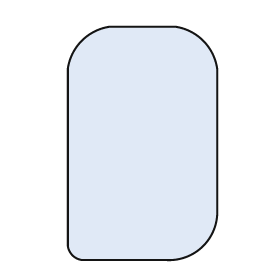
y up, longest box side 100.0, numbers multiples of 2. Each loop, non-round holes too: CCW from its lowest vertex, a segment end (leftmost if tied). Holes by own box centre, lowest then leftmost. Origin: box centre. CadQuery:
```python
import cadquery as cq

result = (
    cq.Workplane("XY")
    .moveTo(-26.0, -50.0)
    .lineTo(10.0, -50.0)
    .threePointArc((26.0, -44.0), (32.0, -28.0))
    .lineTo(32.0, 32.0)
    .threePointArc((26.0, 44.0), (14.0, 50.0))
    .lineTo(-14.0, 50.0)
    .threePointArc((-26.0, 44.0), (-32.0, 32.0))
    .lineTo(-32.0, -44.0)
    .threePointArc((-30.0, -48.0), (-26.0, -50.0))
    .close()
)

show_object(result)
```